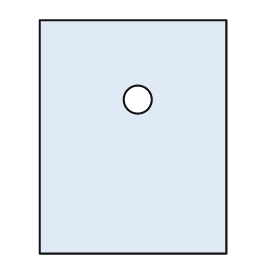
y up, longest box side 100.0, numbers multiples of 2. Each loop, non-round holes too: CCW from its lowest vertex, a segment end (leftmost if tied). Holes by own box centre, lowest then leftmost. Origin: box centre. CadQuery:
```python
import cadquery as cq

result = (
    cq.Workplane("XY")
    .moveTo(-40.0, -50.0)
    .lineTo(40.0, -50.0)
    .lineTo(40.0, 50.0)
    .lineTo(-40.0, 50.0)
    .close()
    .moveTo(2.0, 16.0)
    .circle(6.0)
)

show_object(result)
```